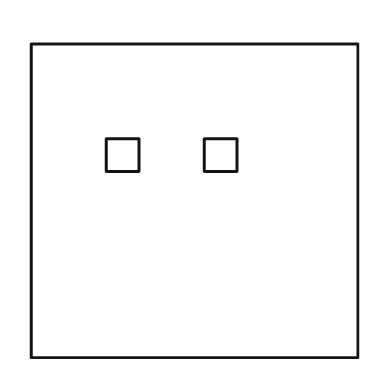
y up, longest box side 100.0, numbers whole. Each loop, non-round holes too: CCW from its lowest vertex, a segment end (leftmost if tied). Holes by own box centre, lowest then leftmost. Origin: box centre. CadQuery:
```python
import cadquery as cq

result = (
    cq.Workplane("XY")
    .moveTo(-50.0, -48.0)
    .lineTo(50.0, -48.0)
    .lineTo(50.0, 48.0)
    .lineTo(-50.0, 48.0)
    .close()
    .moveTo(-27.0, 9.0)
    .lineTo(-17.0, 9.0)
    .lineTo(-17.0, 19.0)
    .lineTo(-27.0, 19.0)
    .close()
    .moveTo(3.0, 9.0)
    .lineTo(13.0, 9.0)
    .lineTo(13.0, 19.0)
    .lineTo(3.0, 19.0)
    .close()
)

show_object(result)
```